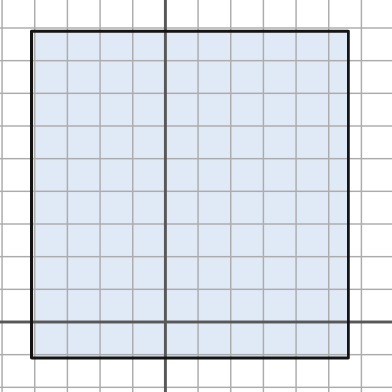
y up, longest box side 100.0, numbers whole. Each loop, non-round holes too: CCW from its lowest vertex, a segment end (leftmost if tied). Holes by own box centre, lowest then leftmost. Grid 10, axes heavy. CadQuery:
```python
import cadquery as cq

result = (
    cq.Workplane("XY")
    .moveTo(-41.0, -11.0)
    .lineTo(56.0, -11.0)
    .lineTo(56.0, 89.0)
    .lineTo(-41.0, 89.0)
    .close()
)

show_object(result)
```